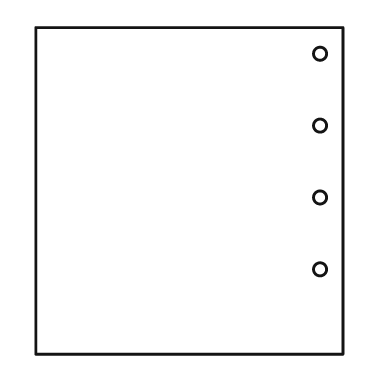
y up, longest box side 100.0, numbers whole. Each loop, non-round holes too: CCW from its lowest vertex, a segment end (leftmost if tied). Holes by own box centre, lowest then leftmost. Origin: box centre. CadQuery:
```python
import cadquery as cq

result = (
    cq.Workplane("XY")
    .moveTo(-47.0, -50.0)
    .lineTo(47.0, -50.0)
    .lineTo(47.0, 50.0)
    .lineTo(-47.0, 50.0)
    .close()
    .moveTo(40.0, -24.0)
    .circle(2.0)
    .moveTo(40.0, -2.0)
    .circle(2.0)
    .moveTo(40.0, 20.0)
    .circle(2.0)
    .moveTo(40.0, 42.0)
    .circle(2.0)
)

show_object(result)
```